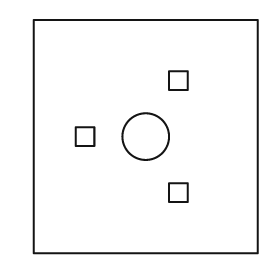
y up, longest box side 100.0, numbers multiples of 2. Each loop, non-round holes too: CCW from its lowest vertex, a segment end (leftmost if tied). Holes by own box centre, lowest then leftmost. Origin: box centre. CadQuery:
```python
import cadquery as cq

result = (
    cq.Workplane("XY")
    .moveTo(-48.0, -50.0)
    .lineTo(48.0, -50.0)
    .lineTo(48.0, 50.0)
    .lineTo(-48.0, 50.0)
    .close()
    .moveTo(10.0, -28.0)
    .lineTo(18.0, -28.0)
    .lineTo(18.0, -20.0)
    .lineTo(10.0, -20.0)
    .close()
    .moveTo(-30.0, -4.0)
    .lineTo(-22.0, -4.0)
    .lineTo(-22.0, 4.0)
    .lineTo(-30.0, 4.0)
    .close()
    .moveTo(0.0, 0.0)
    .circle(10.0)
    .moveTo(10.0, 20.0)
    .lineTo(18.0, 20.0)
    .lineTo(18.0, 28.0)
    .lineTo(10.0, 28.0)
    .close()
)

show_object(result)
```